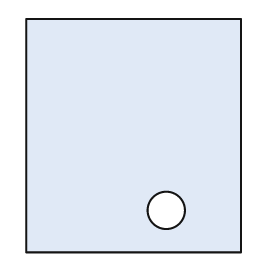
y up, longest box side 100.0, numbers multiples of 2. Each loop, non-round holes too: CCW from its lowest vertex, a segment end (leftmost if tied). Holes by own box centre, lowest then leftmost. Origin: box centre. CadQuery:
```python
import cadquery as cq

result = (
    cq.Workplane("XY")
    .moveTo(-46.0, -50.0)
    .lineTo(46.0, -50.0)
    .lineTo(46.0, 50.0)
    .lineTo(-46.0, 50.0)
    .close()
    .moveTo(14.0, -32.0)
    .circle(8.0)
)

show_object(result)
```